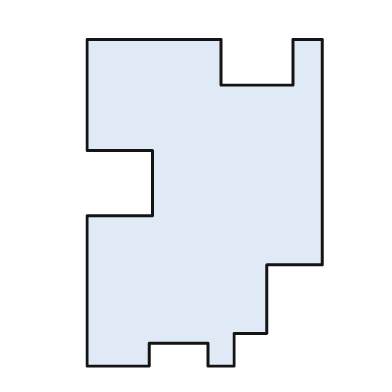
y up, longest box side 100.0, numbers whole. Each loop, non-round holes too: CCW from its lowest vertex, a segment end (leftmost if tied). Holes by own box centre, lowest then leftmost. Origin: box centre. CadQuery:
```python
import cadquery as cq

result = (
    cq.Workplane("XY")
    .moveTo(-36.0, -50.0)
    .lineTo(-17.0, -50.0)
    .lineTo(-17.0, -43.0)
    .lineTo(1.0, -43.0)
    .lineTo(1.0, -50.0)
    .lineTo(9.0, -50.0)
    .lineTo(9.0, -40.0)
    .lineTo(19.0, -40.0)
    .lineTo(19.0, -19.0)
    .lineTo(36.0, -19.0)
    .lineTo(36.0, 50.0)
    .lineTo(27.0, 50.0)
    .lineTo(27.0, 36.0)
    .lineTo(5.0, 36.0)
    .lineTo(5.0, 50.0)
    .lineTo(-36.0, 50.0)
    .lineTo(-36.0, 16.0)
    .lineTo(-16.0, 16.0)
    .lineTo(-16.0, -4.0)
    .lineTo(-36.0, -4.0)
    .close()
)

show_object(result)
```